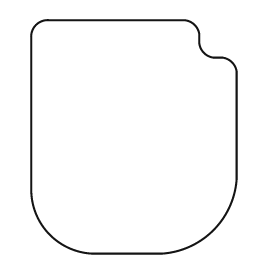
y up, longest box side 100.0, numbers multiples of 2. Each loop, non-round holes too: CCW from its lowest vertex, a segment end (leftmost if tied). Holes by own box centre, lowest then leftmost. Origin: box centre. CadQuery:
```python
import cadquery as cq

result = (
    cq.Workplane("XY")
    .moveTo(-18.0, -50.0)
    .lineTo(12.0, -50.0)
    .threePointArc((34.0, -40.0), (44.0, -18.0))
    .lineTo(44.0, 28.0)
    .threePointArc((42.0, 32.0), (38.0, 34.0))
    .lineTo(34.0, 34.0)
    .threePointArc((30.0, 36.0), (28.0, 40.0))
    .lineTo(28.0, 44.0)
    .threePointArc((26.0, 48.0), (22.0, 50.0))
    .lineTo(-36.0, 50.0)
    .threePointArc((-42.0, 48.0), (-44.0, 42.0))
    .lineTo(-44.0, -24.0)
    .threePointArc((-36.0, -42.0), (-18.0, -50.0))
    .close()
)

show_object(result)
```